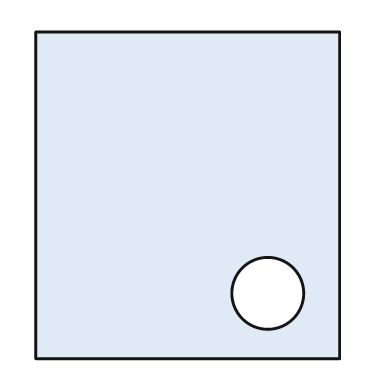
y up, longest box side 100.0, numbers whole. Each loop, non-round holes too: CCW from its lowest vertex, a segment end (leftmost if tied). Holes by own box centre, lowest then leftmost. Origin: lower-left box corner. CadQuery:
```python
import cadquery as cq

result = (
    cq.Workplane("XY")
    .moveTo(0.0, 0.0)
    .lineTo(93.0, 0.0)
    .lineTo(93.0, 100.0)
    .lineTo(0.0, 100.0)
    .close()
    .moveTo(71.0, 20.0)
    .circle(11.0)
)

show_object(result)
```